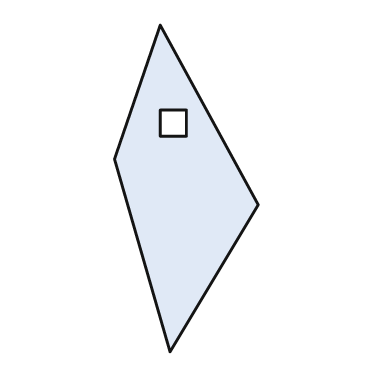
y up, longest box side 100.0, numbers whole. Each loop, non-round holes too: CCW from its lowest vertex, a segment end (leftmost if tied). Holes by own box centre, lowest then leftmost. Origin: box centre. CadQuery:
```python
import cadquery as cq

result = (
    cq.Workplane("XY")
    .moveTo(-5.0, -50.0)
    .lineTo(22.0, -5.0)
    .lineTo(-8.0, 50.0)
    .lineTo(-22.0, 9.0)
    .close()
    .moveTo(-8.0, 16.0)
    .lineTo(0.0, 16.0)
    .lineTo(0.0, 24.0)
    .lineTo(-8.0, 24.0)
    .close()
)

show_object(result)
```